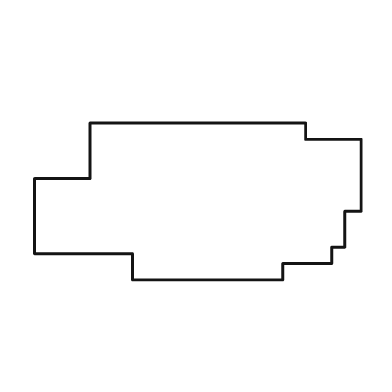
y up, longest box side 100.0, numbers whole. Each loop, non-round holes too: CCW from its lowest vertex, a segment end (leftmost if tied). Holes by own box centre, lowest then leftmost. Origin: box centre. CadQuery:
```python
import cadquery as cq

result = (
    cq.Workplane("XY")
    .moveTo(-20.0, -24.0)
    .lineTo(26.0, -24.0)
    .lineTo(26.0, -19.0)
    .lineTo(41.0, -19.0)
    .lineTo(41.0, -14.0)
    .lineTo(45.0, -14.0)
    .lineTo(45.0, -3.0)
    .lineTo(50.0, -3.0)
    .lineTo(50.0, 19.0)
    .lineTo(33.0, 19.0)
    .lineTo(33.0, 24.0)
    .lineTo(-33.0, 24.0)
    .lineTo(-33.0, 7.0)
    .lineTo(-50.0, 7.0)
    .lineTo(-50.0, -16.0)
    .lineTo(-20.0, -16.0)
    .close()
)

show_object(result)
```